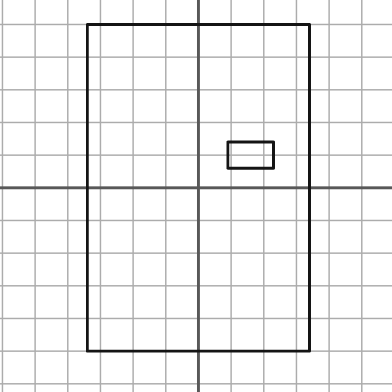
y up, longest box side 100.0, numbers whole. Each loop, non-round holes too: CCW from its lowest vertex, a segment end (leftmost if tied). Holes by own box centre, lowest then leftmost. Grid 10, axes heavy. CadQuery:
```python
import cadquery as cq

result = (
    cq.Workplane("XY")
    .moveTo(-34.0, -50.0)
    .lineTo(34.0, -50.0)
    .lineTo(34.0, 50.0)
    .lineTo(-34.0, 50.0)
    .close()
    .moveTo(9.0, 6.0)
    .lineTo(23.0, 6.0)
    .lineTo(23.0, 14.0)
    .lineTo(9.0, 14.0)
    .close()
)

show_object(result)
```